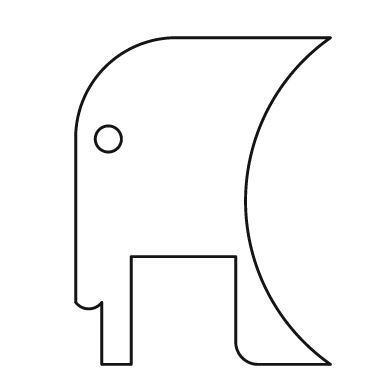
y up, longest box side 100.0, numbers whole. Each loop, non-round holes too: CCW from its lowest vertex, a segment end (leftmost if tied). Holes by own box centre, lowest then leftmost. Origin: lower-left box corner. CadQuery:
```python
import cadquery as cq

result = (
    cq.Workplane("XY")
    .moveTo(8.0, 0.0)
    .lineTo(17.0, 0.0)
    .lineTo(17.0, 33.0)
    .lineTo(49.0, 33.0)
    .lineTo(49.0, 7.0)
    .threePointArc((51.0, 2.0), (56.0, 0.0))
    .lineTo(78.0, 0.0)
    .threePointArc((52.0, 50.0), (78.0, 100.0))
    .lineTo(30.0, 100.0)
    .threePointArc((9.0, 91.0), (0.0, 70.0))
    .lineTo(0.0, 19.0)
    .threePointArc((4.0, 17.0), (8.0, 19.0))
    .close()
    .moveTo(10.0, 69.0)
    .circle(4.0)
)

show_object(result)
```